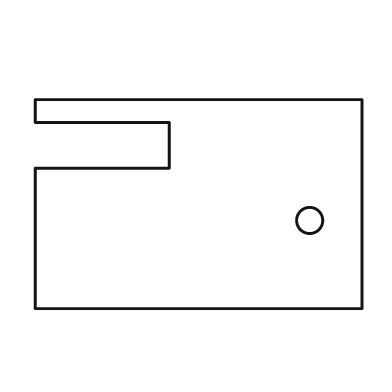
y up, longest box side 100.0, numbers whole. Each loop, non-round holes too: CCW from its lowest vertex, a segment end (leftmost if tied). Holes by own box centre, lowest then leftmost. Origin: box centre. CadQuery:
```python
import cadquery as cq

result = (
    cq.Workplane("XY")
    .moveTo(-50.0, -32.0)
    .lineTo(50.0, -32.0)
    .lineTo(50.0, 32.0)
    .lineTo(-50.0, 32.0)
    .lineTo(-50.0, 25.0)
    .lineTo(-9.0, 25.0)
    .lineTo(-9.0, 11.0)
    .lineTo(-50.0, 11.0)
    .close()
    .moveTo(34.0, -5.0)
    .circle(4.0)
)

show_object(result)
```